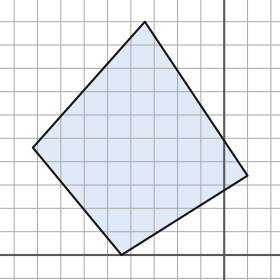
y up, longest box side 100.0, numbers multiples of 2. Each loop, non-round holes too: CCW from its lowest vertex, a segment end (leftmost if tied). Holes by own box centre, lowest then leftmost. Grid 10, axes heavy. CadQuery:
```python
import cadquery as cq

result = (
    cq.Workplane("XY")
    .moveTo(-44.0, 0.0)
    .lineTo(10.0, 34.0)
    .lineTo(-34.0, 100.0)
    .lineTo(-82.0, 46.0)
    .close()
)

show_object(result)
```